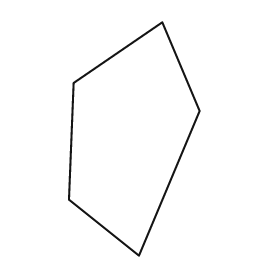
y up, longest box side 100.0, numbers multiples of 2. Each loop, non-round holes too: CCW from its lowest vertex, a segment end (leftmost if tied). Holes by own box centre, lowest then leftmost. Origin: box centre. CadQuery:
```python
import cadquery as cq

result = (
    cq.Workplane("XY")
    .moveTo(2.0, -50.0)
    .lineTo(28.0, 12.0)
    .lineTo(12.0, 50.0)
    .lineTo(-26.0, 24.0)
    .lineTo(-28.0, -26.0)
    .close()
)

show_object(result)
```